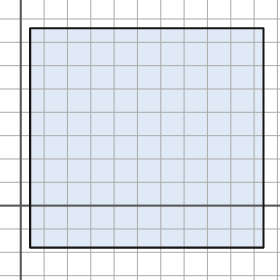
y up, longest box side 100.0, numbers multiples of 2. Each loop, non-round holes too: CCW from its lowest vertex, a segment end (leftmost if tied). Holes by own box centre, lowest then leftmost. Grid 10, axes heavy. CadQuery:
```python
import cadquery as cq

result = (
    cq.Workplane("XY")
    .moveTo(4.0, -18.0)
    .lineTo(104.0, -18.0)
    .lineTo(104.0, 76.0)
    .lineTo(4.0, 76.0)
    .close()
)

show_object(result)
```